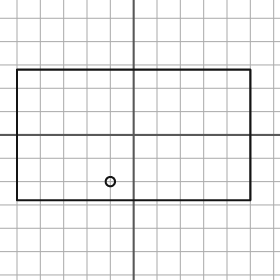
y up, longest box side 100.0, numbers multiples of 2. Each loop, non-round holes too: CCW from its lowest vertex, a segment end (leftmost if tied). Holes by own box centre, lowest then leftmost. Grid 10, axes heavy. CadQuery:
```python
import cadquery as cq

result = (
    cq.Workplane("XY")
    .moveTo(-50.0, -28.0)
    .lineTo(50.0, -28.0)
    .lineTo(50.0, 28.0)
    .lineTo(-50.0, 28.0)
    .close()
    .moveTo(-10.0, -20.0)
    .circle(2.0)
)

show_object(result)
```